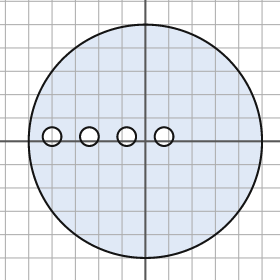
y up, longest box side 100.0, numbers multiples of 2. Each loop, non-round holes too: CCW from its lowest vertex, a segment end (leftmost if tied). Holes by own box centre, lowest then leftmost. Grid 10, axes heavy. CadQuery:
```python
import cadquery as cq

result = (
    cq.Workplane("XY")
    .moveTo(0.0, 0.0)
    .circle(50.0)
    .moveTo(-40.0, 2.0)
    .circle(4.0)
    .moveTo(-24.0, 2.0)
    .circle(4.0)
    .moveTo(-8.0, 2.0)
    .circle(4.0)
    .moveTo(8.0, 2.0)
    .circle(4.0)
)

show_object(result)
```